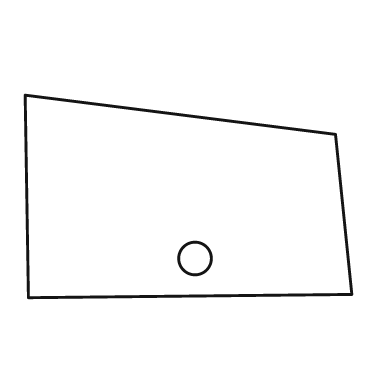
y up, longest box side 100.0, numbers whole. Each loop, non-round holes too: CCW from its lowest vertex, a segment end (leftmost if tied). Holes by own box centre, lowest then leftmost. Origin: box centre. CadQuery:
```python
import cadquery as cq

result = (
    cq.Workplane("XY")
    .moveTo(-49.0, -31.0)
    .lineTo(50.0, -30.0)
    .lineTo(45.0, 19.0)
    .lineTo(-50.0, 31.0)
    .close()
    .moveTo(2.0, -19.0)
    .circle(5.0)
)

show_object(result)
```